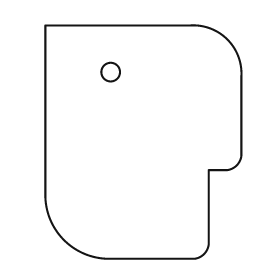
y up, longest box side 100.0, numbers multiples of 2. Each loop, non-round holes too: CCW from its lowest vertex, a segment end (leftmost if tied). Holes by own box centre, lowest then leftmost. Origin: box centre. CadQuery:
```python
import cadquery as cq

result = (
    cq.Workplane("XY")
    .moveTo(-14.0, -50.0)
    .lineTo(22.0, -50.0)
    .threePointArc((26.0, -48.0), (28.0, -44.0))
    .lineTo(28.0, -12.0)
    .lineTo(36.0, -12.0)
    .threePointArc((40.0, -10.0), (42.0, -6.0))
    .lineTo(42.0, 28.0)
    .threePointArc((36.0, 44.0), (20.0, 50.0))
    .lineTo(-42.0, 50.0)
    .lineTo(-42.0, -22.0)
    .threePointArc((-34.0, -42.0), (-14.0, -50.0))
    .close()
    .moveTo(-14.0, 30.0)
    .circle(4.0)
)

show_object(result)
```